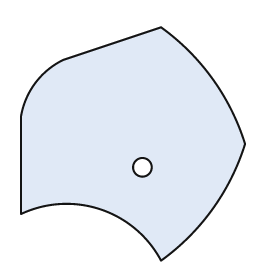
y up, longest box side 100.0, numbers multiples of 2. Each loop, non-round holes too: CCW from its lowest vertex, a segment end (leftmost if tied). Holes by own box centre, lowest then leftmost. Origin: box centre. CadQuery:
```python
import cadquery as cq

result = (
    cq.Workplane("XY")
    .moveTo(12.0, -50.0)
    .threePointArc((34.0, -28.0), (48.0, 0.0))
    .threePointArc((34.0, 28.0), (12.0, 50.0))
    .lineTo(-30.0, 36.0)
    .threePointArc((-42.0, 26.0), (-48.0, 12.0))
    .lineTo(-48.0, -30.0)
    .threePointArc((-14.0, -28.0), (12.0, -50.0))
    .close()
    .moveTo(4.0, -10.0)
    .circle(4.0)
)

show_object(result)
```